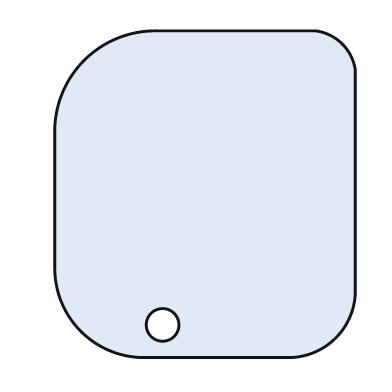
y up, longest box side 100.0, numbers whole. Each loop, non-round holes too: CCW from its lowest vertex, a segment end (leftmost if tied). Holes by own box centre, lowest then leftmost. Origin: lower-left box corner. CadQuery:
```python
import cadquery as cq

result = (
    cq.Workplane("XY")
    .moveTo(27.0, 0.0)
    .lineTo(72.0, 0.0)
    .threePointArc((86.0, 6.0), (92.0, 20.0))
    .lineTo(92.0, 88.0)
    .threePointArc((88.0, 96.0), (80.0, 100.0))
    .lineTo(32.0, 100.0)
    .threePointArc((9.0, 91.0), (0.0, 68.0))
    .lineTo(0.0, 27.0)
    .threePointArc((8.0, 8.0), (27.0, 0.0))
    .close()
    .moveTo(33.0, 10.0)
    .circle(5.0)
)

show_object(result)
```